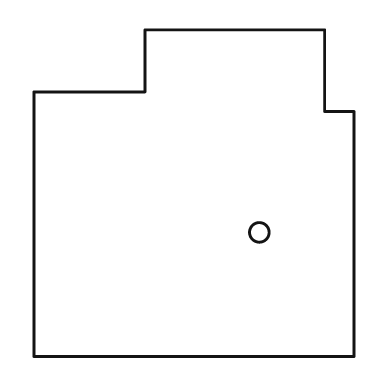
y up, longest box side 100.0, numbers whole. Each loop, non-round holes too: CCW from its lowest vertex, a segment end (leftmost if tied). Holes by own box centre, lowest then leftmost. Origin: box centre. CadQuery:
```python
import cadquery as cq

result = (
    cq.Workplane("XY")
    .moveTo(-49.0, -50.0)
    .lineTo(49.0, -50.0)
    .lineTo(49.0, 25.0)
    .lineTo(40.0, 25.0)
    .lineTo(40.0, 50.0)
    .lineTo(-15.0, 50.0)
    .lineTo(-15.0, 31.0)
    .lineTo(-49.0, 31.0)
    .close()
    .moveTo(20.0, -12.0)
    .circle(3.0)
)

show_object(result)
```